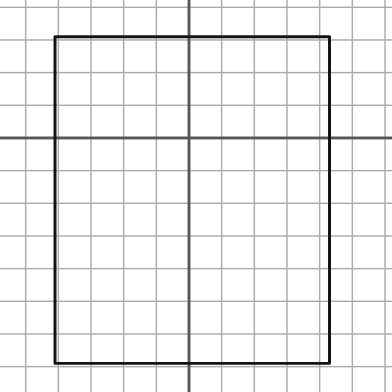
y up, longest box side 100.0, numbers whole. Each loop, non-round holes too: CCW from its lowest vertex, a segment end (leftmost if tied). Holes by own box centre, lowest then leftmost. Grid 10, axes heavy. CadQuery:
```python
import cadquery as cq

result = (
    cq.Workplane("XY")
    .moveTo(-41.0, -69.0)
    .lineTo(43.0, -69.0)
    .lineTo(43.0, 31.0)
    .lineTo(-41.0, 31.0)
    .close()
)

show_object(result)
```